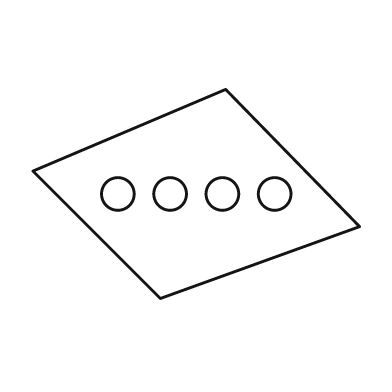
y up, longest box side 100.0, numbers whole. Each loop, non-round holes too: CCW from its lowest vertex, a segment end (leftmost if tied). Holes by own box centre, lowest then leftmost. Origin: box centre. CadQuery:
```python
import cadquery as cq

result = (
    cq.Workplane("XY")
    .moveTo(-11.0, -32.0)
    .lineTo(50.0, -10.0)
    .lineTo(9.0, 32.0)
    .lineTo(-50.0, 7.0)
    .close()
    .moveTo(-24.0, 0.0)
    .circle(5.0)
    .moveTo(-8.0, 0.0)
    .circle(5.0)
    .moveTo(8.0, 0.0)
    .circle(5.0)
    .moveTo(24.0, 0.0)
    .circle(5.0)
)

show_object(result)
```